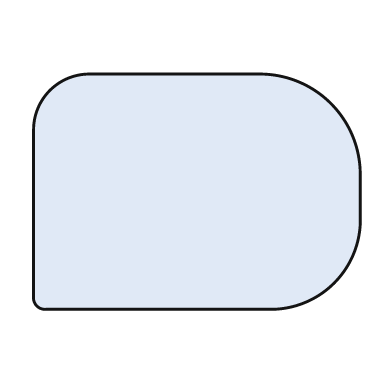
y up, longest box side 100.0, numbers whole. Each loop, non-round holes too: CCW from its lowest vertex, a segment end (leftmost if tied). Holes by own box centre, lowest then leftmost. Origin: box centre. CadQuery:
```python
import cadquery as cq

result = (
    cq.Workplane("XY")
    .moveTo(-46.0, -36.0)
    .lineTo(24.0, -36.0)
    .threePointArc((42.0, -28.0), (50.0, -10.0))
    .lineTo(50.0, 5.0)
    .threePointArc((41.0, 27.0), (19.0, 36.0))
    .lineTo(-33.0, 36.0)
    .threePointArc((-45.0, 31.0), (-50.0, 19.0))
    .lineTo(-50.0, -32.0)
    .threePointArc((-49.0, -35.0), (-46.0, -36.0))
    .close()
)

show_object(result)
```